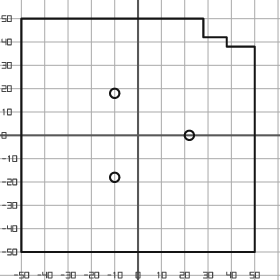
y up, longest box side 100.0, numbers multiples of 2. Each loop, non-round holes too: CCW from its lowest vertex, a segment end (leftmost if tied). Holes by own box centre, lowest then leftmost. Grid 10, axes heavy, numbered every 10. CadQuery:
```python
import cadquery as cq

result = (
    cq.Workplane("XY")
    .moveTo(-50.0, -50.0)
    .lineTo(50.0, -50.0)
    .lineTo(50.0, 38.0)
    .lineTo(38.0, 38.0)
    .lineTo(38.0, 42.0)
    .lineTo(28.0, 42.0)
    .lineTo(28.0, 50.0)
    .lineTo(-50.0, 50.0)
    .close()
    .moveTo(-10.0, -18.0)
    .circle(2.0)
    .moveTo(22.0, 0.0)
    .circle(2.0)
    .moveTo(-10.0, 18.0)
    .circle(2.0)
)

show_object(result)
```